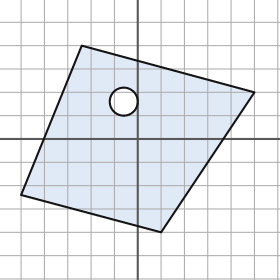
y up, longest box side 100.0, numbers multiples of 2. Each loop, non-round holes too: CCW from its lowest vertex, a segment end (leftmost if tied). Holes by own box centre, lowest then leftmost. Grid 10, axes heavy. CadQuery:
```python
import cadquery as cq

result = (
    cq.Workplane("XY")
    .moveTo(10.0, -40.0)
    .lineTo(50.0, 20.0)
    .lineTo(-24.0, 40.0)
    .lineTo(-50.0, -24.0)
    .close()
    .moveTo(-6.0, 16.0)
    .circle(6.0)
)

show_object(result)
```